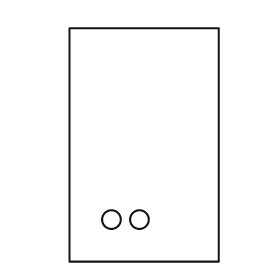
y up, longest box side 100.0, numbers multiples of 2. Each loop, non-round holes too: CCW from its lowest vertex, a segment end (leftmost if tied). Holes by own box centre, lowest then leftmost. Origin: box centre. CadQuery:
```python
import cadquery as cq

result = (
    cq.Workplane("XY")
    .moveTo(-32.0, -50.0)
    .lineTo(32.0, -50.0)
    .lineTo(32.0, 50.0)
    .lineTo(-32.0, 50.0)
    .close()
    .moveTo(-14.0, -32.0)
    .circle(4.0)
    .moveTo(-2.0, -32.0)
    .circle(4.0)
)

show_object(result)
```